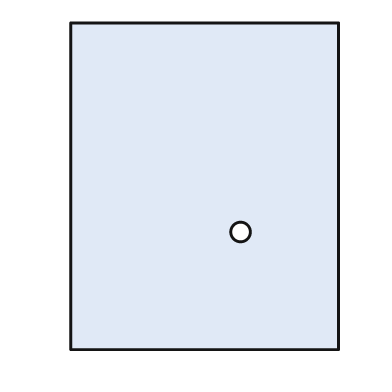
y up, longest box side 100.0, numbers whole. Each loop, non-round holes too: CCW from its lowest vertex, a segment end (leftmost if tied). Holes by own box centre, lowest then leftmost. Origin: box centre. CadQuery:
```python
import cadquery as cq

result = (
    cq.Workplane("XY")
    .moveTo(-41.0, -50.0)
    .lineTo(41.0, -50.0)
    .lineTo(41.0, 50.0)
    .lineTo(-41.0, 50.0)
    .close()
    .moveTo(11.0, -14.0)
    .circle(3.0)
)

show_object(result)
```